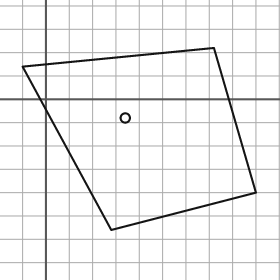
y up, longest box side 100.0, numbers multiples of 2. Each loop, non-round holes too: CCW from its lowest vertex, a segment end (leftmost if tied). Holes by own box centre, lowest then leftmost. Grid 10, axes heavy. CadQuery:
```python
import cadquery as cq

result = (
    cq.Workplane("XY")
    .moveTo(28.0, -56.0)
    .lineTo(90.0, -40.0)
    .lineTo(72.0, 22.0)
    .lineTo(-10.0, 14.0)
    .close()
    .moveTo(34.0, -8.0)
    .circle(2.0)
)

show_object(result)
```